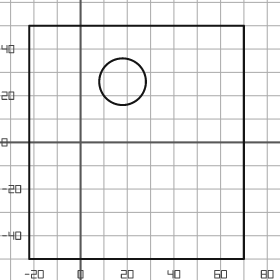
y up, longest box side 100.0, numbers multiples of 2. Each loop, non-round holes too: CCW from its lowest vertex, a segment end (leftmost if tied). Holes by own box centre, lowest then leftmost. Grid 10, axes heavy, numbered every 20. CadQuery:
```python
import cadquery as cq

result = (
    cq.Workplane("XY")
    .moveTo(-22.0, -50.0)
    .lineTo(70.0, -50.0)
    .lineTo(70.0, 50.0)
    .lineTo(-22.0, 50.0)
    .close()
    .moveTo(18.0, 26.0)
    .circle(10.0)
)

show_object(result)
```